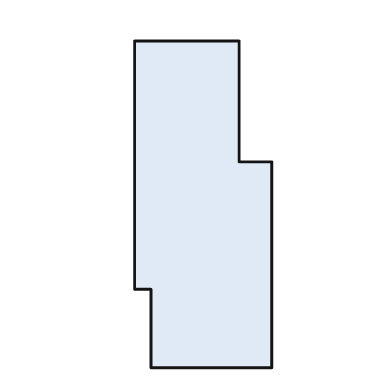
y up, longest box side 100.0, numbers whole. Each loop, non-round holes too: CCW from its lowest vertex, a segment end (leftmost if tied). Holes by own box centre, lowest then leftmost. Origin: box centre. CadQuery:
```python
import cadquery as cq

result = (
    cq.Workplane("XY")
    .moveTo(-16.0, -50.0)
    .lineTo(21.0, -50.0)
    .lineTo(21.0, 13.0)
    .lineTo(11.0, 13.0)
    .lineTo(11.0, 50.0)
    .lineTo(-21.0, 50.0)
    .lineTo(-21.0, -26.0)
    .lineTo(-16.0, -26.0)
    .close()
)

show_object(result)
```